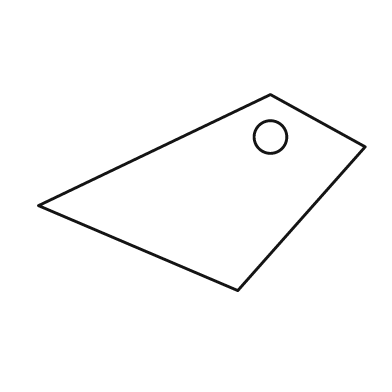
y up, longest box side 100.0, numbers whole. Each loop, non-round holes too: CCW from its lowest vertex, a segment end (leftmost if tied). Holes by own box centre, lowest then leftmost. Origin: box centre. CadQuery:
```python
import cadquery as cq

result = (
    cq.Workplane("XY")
    .moveTo(11.0, -30.0)
    .lineTo(50.0, 14.0)
    .lineTo(21.0, 30.0)
    .lineTo(-50.0, -4.0)
    .close()
    .moveTo(21.0, 17.0)
    .circle(5.0)
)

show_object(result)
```